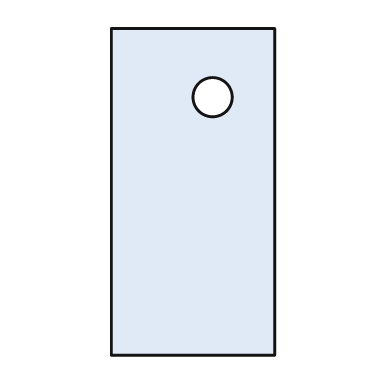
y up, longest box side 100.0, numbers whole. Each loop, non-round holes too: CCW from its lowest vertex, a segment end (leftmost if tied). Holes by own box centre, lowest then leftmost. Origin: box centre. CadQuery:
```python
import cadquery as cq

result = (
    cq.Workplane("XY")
    .moveTo(-25.0, -50.0)
    .lineTo(25.0, -50.0)
    .lineTo(25.0, 50.0)
    .lineTo(-25.0, 50.0)
    .close()
    .moveTo(6.0, 29.0)
    .circle(6.0)
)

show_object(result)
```